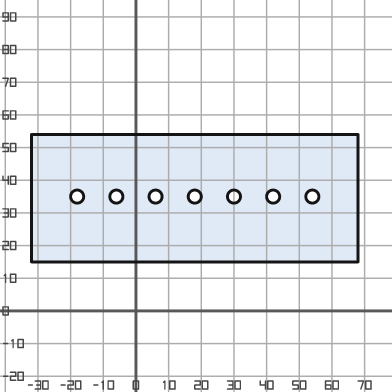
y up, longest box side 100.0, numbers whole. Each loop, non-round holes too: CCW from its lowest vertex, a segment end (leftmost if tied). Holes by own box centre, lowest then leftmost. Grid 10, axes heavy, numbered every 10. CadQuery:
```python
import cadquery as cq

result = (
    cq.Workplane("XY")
    .moveTo(-32.0, 15.0)
    .lineTo(68.0, 15.0)
    .lineTo(68.0, 54.0)
    .lineTo(-32.0, 54.0)
    .close()
    .moveTo(-18.0, 35.0)
    .circle(2.0)
    .moveTo(-6.0, 35.0)
    .circle(2.0)
    .moveTo(6.0, 35.0)
    .circle(2.0)
    .moveTo(18.0, 35.0)
    .circle(2.0)
    .moveTo(30.0, 35.0)
    .circle(2.0)
    .moveTo(42.0, 35.0)
    .circle(2.0)
    .moveTo(54.0, 35.0)
    .circle(2.0)
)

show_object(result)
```